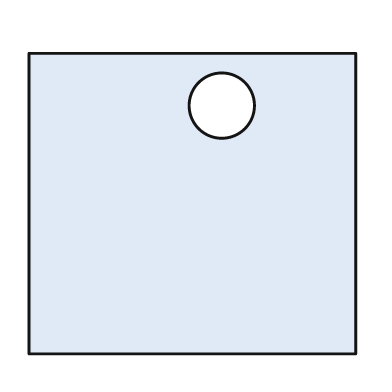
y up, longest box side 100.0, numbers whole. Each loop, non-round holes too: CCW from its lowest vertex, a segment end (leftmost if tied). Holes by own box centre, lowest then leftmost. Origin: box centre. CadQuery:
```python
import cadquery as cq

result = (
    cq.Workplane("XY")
    .moveTo(-50.0, -46.0)
    .lineTo(50.0, -46.0)
    .lineTo(50.0, 46.0)
    .lineTo(-50.0, 46.0)
    .close()
    .moveTo(9.0, 30.0)
    .circle(10.0)
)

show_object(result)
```